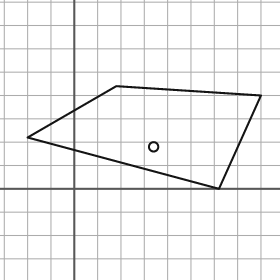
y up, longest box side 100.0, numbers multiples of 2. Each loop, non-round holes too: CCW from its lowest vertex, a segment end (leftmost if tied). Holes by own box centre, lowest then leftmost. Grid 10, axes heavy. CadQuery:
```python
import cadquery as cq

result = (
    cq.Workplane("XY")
    .moveTo(62.0, 0.0)
    .lineTo(80.0, 40.0)
    .lineTo(18.0, 44.0)
    .lineTo(-20.0, 22.0)
    .close()
    .moveTo(34.0, 18.0)
    .circle(2.0)
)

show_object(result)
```